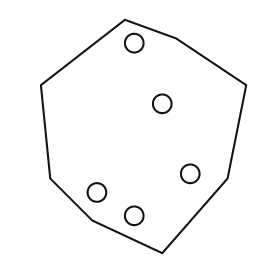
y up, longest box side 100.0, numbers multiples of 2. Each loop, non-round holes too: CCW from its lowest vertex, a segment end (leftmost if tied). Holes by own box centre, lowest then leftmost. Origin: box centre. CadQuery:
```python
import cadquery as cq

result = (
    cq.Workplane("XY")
    .moveTo(8.0, -50.0)
    .lineTo(36.0, -18.0)
    .lineTo(44.0, 22.0)
    .lineTo(14.0, 42.0)
    .lineTo(-8.0, 50.0)
    .lineTo(-44.0, 22.0)
    .lineTo(-40.0, -18.0)
    .lineTo(-22.0, -36.0)
    .close()
    .moveTo(-4.0, -34.0)
    .circle(4.0)
    .moveTo(-20.0, -24.0)
    .circle(4.0)
    .moveTo(20.0, -16.0)
    .circle(4.0)
    .moveTo(8.0, 14.0)
    .circle(4.0)
    .moveTo(-4.0, 40.0)
    .circle(4.0)
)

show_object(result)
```